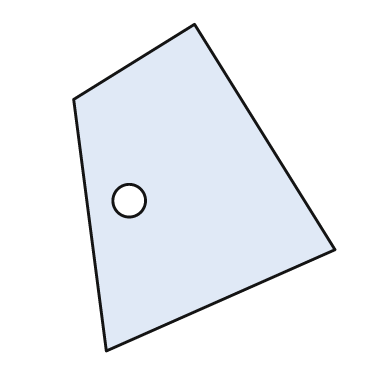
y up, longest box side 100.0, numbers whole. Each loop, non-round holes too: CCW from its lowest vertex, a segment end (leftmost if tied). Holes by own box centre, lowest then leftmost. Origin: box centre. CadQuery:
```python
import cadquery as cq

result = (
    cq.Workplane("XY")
    .moveTo(-30.0, -50.0)
    .lineTo(40.0, -19.0)
    .lineTo(-3.0, 50.0)
    .lineTo(-40.0, 27.0)
    .close()
    .moveTo(-23.0, -4.0)
    .circle(5.0)
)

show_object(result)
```